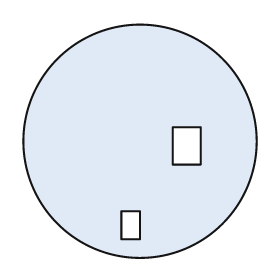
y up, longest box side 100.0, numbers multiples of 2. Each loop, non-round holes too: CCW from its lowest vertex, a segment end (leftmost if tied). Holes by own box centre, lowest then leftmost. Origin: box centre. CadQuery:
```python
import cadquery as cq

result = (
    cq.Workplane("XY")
    .moveTo(0.0, 0.0)
    .circle(50.0)
    .moveTo(-8.0, -42.0)
    .lineTo(0.0, -42.0)
    .lineTo(0.0, -30.0)
    .lineTo(-8.0, -30.0)
    .close()
    .moveTo(14.0, -10.0)
    .lineTo(26.0, -10.0)
    .lineTo(26.0, 6.0)
    .lineTo(14.0, 6.0)
    .close()
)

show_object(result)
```